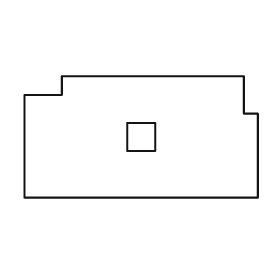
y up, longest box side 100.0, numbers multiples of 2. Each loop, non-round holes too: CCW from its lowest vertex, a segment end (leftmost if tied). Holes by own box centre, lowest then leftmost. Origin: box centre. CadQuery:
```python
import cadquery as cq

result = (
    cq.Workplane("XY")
    .moveTo(-50.0, -26.0)
    .lineTo(50.0, -26.0)
    .lineTo(50.0, 10.0)
    .lineTo(44.0, 10.0)
    .lineTo(44.0, 26.0)
    .lineTo(-34.0, 26.0)
    .lineTo(-34.0, 18.0)
    .lineTo(-50.0, 18.0)
    .close()
    .moveTo(-6.0, -6.0)
    .lineTo(6.0, -6.0)
    .lineTo(6.0, 6.0)
    .lineTo(-6.0, 6.0)
    .close()
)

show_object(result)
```